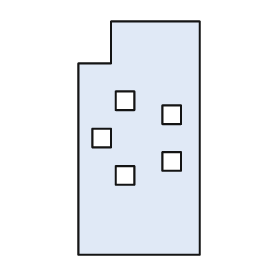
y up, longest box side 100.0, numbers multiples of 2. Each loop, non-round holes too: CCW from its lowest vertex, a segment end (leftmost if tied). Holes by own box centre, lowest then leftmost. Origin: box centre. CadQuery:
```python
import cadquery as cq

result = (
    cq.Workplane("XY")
    .moveTo(-26.0, -50.0)
    .lineTo(26.0, -50.0)
    .lineTo(26.0, 50.0)
    .lineTo(-12.0, 50.0)
    .lineTo(-12.0, 32.0)
    .lineTo(-26.0, 32.0)
    .close()
    .moveTo(-10.0, -20.0)
    .lineTo(-2.0, -20.0)
    .lineTo(-2.0, -12.0)
    .lineTo(-10.0, -12.0)
    .close()
    .moveTo(10.0, -14.0)
    .lineTo(18.0, -14.0)
    .lineTo(18.0, -6.0)
    .lineTo(10.0, -6.0)
    .close()
    .moveTo(-20.0, -4.0)
    .lineTo(-12.0, -4.0)
    .lineTo(-12.0, 4.0)
    .lineTo(-20.0, 4.0)
    .close()
    .moveTo(10.0, 6.0)
    .lineTo(18.0, 6.0)
    .lineTo(18.0, 14.0)
    .lineTo(10.0, 14.0)
    .close()
    .moveTo(-10.0, 12.0)
    .lineTo(-2.0, 12.0)
    .lineTo(-2.0, 20.0)
    .lineTo(-10.0, 20.0)
    .close()
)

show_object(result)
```